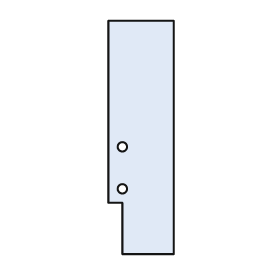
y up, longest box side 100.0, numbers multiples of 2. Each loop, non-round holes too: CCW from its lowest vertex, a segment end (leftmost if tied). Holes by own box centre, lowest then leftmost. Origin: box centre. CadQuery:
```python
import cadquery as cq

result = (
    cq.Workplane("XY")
    .moveTo(-8.0, -50.0)
    .lineTo(14.0, -50.0)
    .lineTo(14.0, 50.0)
    .lineTo(-14.0, 50.0)
    .lineTo(-14.0, -28.0)
    .lineTo(-8.0, -28.0)
    .close()
    .moveTo(-8.0, -22.0)
    .circle(2.0)
    .moveTo(-8.0, -4.0)
    .circle(2.0)
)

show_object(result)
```